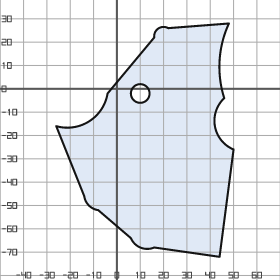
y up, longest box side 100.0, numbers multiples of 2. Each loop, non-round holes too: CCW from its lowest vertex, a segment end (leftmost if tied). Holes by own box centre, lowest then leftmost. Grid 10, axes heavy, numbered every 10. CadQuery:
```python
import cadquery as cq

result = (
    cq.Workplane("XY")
    .moveTo(44.0, -72.0)
    .lineTo(50.0, -26.0)
    .threePointArc((42.0, -16.0), (46.0, -4.0))
    .threePointArc((44.0, 12.0), (48.0, 28.0))
    .lineTo(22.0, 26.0)
    .threePointArc((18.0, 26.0), (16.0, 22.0))
    .lineTo(-4.0, -2.0)
    .threePointArc((-12.0, -14.0), (-26.0, -16.0))
    .lineTo(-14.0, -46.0)
    .threePointArc((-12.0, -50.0), (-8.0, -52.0))
    .lineTo(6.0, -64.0)
    .threePointArc((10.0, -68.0), (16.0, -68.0))
    .close()
    .moveTo(10.0, -2.0)
    .circle(4.0)
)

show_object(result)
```